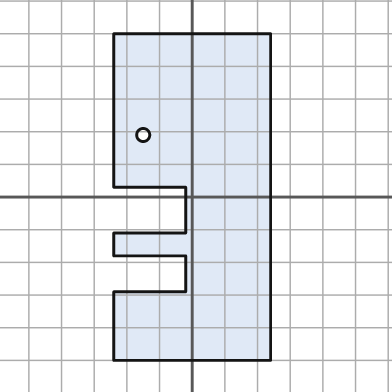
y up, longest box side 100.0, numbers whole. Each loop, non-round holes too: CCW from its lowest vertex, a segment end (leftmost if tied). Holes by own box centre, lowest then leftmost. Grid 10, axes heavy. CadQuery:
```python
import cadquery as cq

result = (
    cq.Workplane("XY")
    .moveTo(-24.0, -50.0)
    .lineTo(24.0, -50.0)
    .lineTo(24.0, 50.0)
    .lineTo(-24.0, 50.0)
    .lineTo(-24.0, 3.0)
    .lineTo(-2.0, 3.0)
    .lineTo(-2.0, -11.0)
    .lineTo(-24.0, -11.0)
    .lineTo(-24.0, -18.0)
    .lineTo(-2.0, -18.0)
    .lineTo(-2.0, -29.0)
    .lineTo(-24.0, -29.0)
    .close()
    .moveTo(-15.0, 19.0)
    .circle(2.0)
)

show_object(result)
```